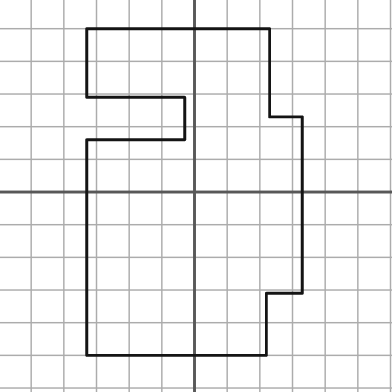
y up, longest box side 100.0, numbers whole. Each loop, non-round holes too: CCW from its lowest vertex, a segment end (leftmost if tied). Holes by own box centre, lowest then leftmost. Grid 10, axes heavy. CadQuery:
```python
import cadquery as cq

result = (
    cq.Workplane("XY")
    .moveTo(-33.0, -50.0)
    .lineTo(22.0, -50.0)
    .lineTo(22.0, -31.0)
    .lineTo(33.0, -31.0)
    .lineTo(33.0, 23.0)
    .lineTo(23.0, 23.0)
    .lineTo(23.0, 50.0)
    .lineTo(-33.0, 50.0)
    .lineTo(-33.0, 29.0)
    .lineTo(-3.0, 29.0)
    .lineTo(-3.0, 16.0)
    .lineTo(-33.0, 16.0)
    .close()
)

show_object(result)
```